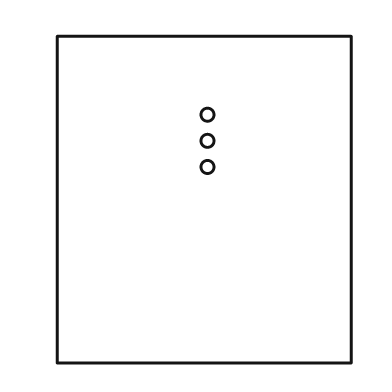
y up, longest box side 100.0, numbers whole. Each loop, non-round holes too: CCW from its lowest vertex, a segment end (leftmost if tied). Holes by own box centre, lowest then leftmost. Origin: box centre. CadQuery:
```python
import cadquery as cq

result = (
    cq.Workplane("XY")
    .moveTo(-45.0, -50.0)
    .lineTo(45.0, -50.0)
    .lineTo(45.0, 50.0)
    .lineTo(-45.0, 50.0)
    .close()
    .moveTo(1.0, 10.0)
    .circle(2.0)
    .moveTo(1.0, 18.0)
    .circle(2.0)
    .moveTo(1.0, 26.0)
    .circle(2.0)
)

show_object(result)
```